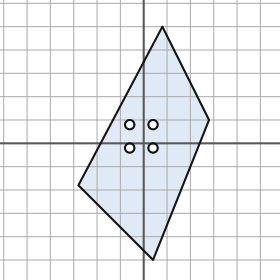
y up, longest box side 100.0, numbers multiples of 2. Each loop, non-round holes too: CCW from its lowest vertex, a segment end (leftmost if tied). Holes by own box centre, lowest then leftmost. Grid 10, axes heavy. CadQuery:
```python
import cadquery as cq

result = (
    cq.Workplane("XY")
    .moveTo(4.0, -50.0)
    .lineTo(28.0, 10.0)
    .lineTo(8.0, 50.0)
    .lineTo(-28.0, -18.0)
    .close()
    .moveTo(-6.0, -2.0)
    .circle(2.0)
    .moveTo(4.0, -2.0)
    .circle(2.0)
    .moveTo(-6.0, 8.0)
    .circle(2.0)
    .moveTo(4.0, 8.0)
    .circle(2.0)
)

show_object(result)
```